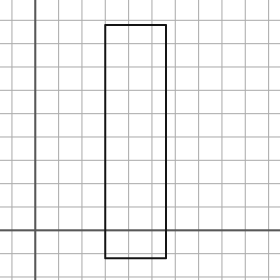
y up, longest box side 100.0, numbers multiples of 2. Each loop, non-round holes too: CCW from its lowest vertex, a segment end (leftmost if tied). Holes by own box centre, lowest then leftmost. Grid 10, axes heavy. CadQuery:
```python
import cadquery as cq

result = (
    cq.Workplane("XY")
    .moveTo(30.0, -12.0)
    .lineTo(56.0, -12.0)
    .lineTo(56.0, 88.0)
    .lineTo(30.0, 88.0)
    .close()
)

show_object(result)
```